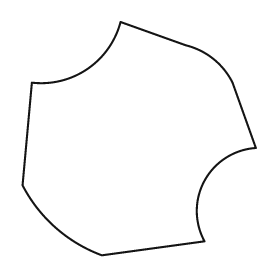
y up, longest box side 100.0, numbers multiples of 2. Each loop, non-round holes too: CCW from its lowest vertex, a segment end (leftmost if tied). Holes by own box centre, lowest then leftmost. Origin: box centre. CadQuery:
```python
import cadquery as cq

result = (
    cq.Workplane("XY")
    .moveTo(-16.0, -50.0)
    .lineTo(28.0, -44.0)
    .threePointArc((28.0, -18.0), (50.0, -4.0))
    .lineTo(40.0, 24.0)
    .threePointArc((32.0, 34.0), (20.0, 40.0))
    .lineTo(-8.0, 50.0)
    .threePointArc((-22.0, 30.0), (-46.0, 24.0))
    .lineTo(-50.0, -20.0)
    .threePointArc((-36.0, -38.0), (-16.0, -50.0))
    .close()
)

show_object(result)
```